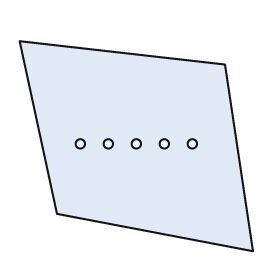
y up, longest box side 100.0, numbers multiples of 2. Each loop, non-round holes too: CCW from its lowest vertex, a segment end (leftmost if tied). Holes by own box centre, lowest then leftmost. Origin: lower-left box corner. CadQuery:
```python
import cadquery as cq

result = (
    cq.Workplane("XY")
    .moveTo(100.0, 0.0)
    .lineTo(88.0, 80.0)
    .lineTo(0.0, 90.0)
    .lineTo(16.0, 16.0)
    .close()
    .moveTo(26.0, 46.0)
    .circle(2.0)
    .moveTo(38.0, 46.0)
    .circle(2.0)
    .moveTo(50.0, 46.0)
    .circle(2.0)
    .moveTo(62.0, 46.0)
    .circle(2.0)
    .moveTo(74.0, 46.0)
    .circle(2.0)
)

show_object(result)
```